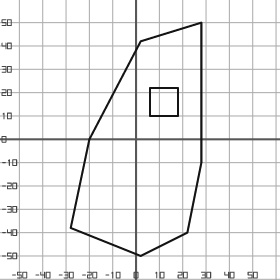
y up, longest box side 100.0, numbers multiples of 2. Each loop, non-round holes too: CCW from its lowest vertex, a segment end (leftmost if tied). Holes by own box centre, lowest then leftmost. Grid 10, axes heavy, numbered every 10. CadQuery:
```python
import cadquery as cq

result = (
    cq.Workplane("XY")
    .moveTo(2.0, -50.0)
    .lineTo(22.0, -40.0)
    .lineTo(28.0, -10.0)
    .lineTo(28.0, 50.0)
    .lineTo(2.0, 42.0)
    .lineTo(-20.0, 0.0)
    .lineTo(-28.0, -38.0)
    .close()
    .moveTo(6.0, 10.0)
    .lineTo(18.0, 10.0)
    .lineTo(18.0, 22.0)
    .lineTo(6.0, 22.0)
    .close()
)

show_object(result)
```